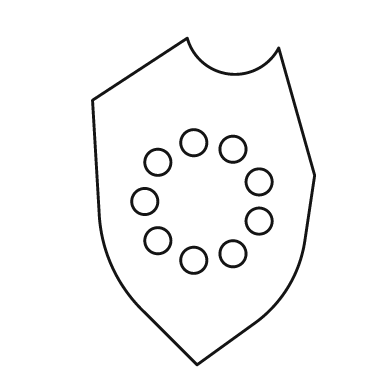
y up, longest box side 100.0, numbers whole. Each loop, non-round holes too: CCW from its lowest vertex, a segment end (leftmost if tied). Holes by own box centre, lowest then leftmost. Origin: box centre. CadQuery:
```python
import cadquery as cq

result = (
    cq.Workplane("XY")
    .moveTo(-2.0, -50.0)
    .lineTo(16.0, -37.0)
    .threePointArc((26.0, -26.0), (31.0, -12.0))
    .lineTo(34.0, 8.0)
    .lineTo(23.0, 47.0)
    .threePointArc((8.0, 39.0), (-5.0, 50.0))
    .lineTo(-34.0, 31.0)
    .lineTo(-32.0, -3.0)
    .threePointArc((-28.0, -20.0), (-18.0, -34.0))
    .close()
    .moveTo(-3.0, -18.0)
    .circle(4.0)
    .moveTo(9.0, -16.0)
    .circle(4.0)
    .moveTo(-14.0, -12.0)
    .circle(4.0)
    .moveTo(17.0, -6.0)
    .circle(4.0)
    .moveTo(-18.0, 0.0)
    .circle(4.0)
    .moveTo(17.0, 6.0)
    .circle(4.0)
    .moveTo(-14.0, 12.0)
    .circle(4.0)
    .moveTo(9.0, 16.0)
    .circle(4.0)
    .moveTo(-3.0, 18.0)
    .circle(4.0)
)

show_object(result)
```